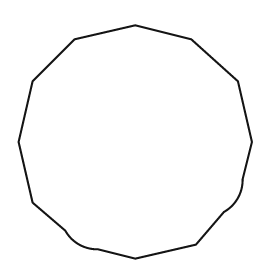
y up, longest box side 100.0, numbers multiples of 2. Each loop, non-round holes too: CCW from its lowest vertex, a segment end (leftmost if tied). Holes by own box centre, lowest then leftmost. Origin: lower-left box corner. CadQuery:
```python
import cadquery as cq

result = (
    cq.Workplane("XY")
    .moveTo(50.0, 0.0)
    .lineTo(76.0, 6.0)
    .lineTo(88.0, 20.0)
    .threePointArc((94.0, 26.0), (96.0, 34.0))
    .lineTo(100.0, 50.0)
    .lineTo(94.0, 76.0)
    .lineTo(74.0, 94.0)
    .lineTo(50.0, 100.0)
    .lineTo(24.0, 94.0)
    .lineTo(6.0, 76.0)
    .lineTo(0.0, 50.0)
    .lineTo(6.0, 24.0)
    .lineTo(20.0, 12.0)
    .threePointArc((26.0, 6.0), (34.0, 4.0))
    .close()
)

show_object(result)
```